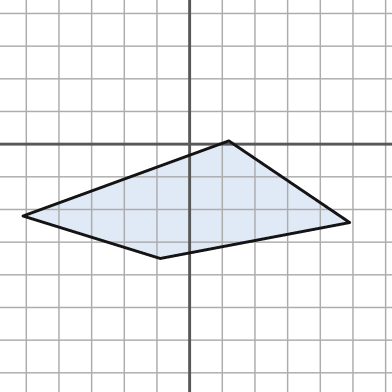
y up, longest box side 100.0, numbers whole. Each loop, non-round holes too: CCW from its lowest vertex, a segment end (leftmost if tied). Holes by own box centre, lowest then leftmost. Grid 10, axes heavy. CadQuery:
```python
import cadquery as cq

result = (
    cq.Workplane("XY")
    .moveTo(-9.0, -35.0)
    .lineTo(49.0, -24.0)
    .lineTo(12.0, 1.0)
    .lineTo(-51.0, -22.0)
    .close()
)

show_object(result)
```